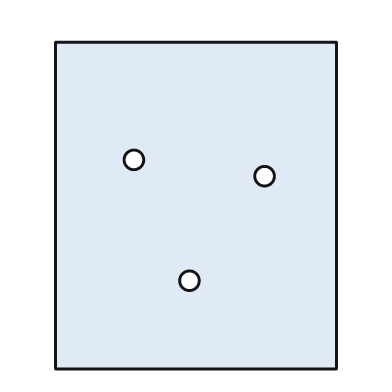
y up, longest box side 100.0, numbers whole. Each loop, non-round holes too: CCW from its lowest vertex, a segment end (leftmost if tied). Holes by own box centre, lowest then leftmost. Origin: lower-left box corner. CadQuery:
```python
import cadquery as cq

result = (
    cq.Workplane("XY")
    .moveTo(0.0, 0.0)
    .lineTo(86.0, 0.0)
    .lineTo(86.0, 100.0)
    .lineTo(0.0, 100.0)
    .close()
    .moveTo(41.0, 27.0)
    .circle(3.0)
    .moveTo(64.0, 59.0)
    .circle(3.0)
    .moveTo(24.0, 64.0)
    .circle(3.0)
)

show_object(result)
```